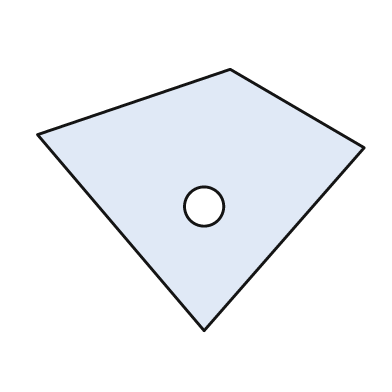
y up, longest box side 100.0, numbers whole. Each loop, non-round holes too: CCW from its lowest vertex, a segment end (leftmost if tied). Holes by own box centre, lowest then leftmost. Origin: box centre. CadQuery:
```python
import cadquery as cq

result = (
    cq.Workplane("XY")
    .moveTo(1.0, -40.0)
    .lineTo(50.0, 16.0)
    .lineTo(9.0, 40.0)
    .lineTo(-50.0, 20.0)
    .close()
    .moveTo(1.0, -2.0)
    .circle(6.0)
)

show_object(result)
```